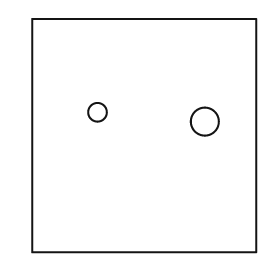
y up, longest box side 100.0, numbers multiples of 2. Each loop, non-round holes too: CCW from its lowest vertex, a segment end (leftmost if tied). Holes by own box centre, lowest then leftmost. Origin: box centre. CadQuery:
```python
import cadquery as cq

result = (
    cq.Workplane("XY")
    .moveTo(-48.0, -50.0)
    .lineTo(48.0, -50.0)
    .lineTo(48.0, 50.0)
    .lineTo(-48.0, 50.0)
    .close()
    .moveTo(26.0, 6.0)
    .circle(6.0)
    .moveTo(-20.0, 10.0)
    .circle(4.0)
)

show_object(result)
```